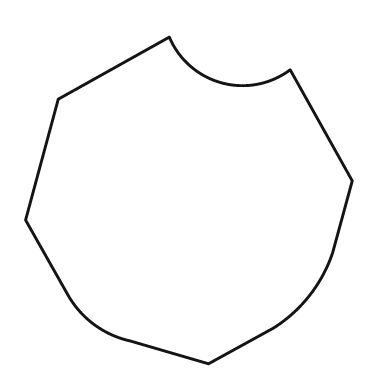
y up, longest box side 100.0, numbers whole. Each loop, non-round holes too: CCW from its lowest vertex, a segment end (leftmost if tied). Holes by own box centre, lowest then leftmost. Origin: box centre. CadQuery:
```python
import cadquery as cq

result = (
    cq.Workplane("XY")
    .moveTo(6.0, -50.0)
    .lineTo(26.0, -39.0)
    .threePointArc((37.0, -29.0), (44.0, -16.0))
    .lineTo(50.0, 6.0)
    .lineTo(31.0, 40.0)
    .threePointArc((10.0, 36.0), (-6.0, 50.0))
    .lineTo(-40.0, 31.0)
    .lineTo(-50.0, -6.0)
    .lineTo(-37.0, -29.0)
    .threePointArc((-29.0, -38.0), (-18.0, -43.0))
    .close()
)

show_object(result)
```